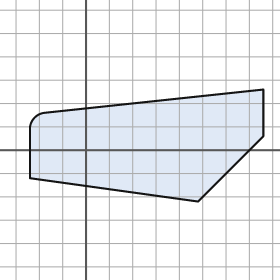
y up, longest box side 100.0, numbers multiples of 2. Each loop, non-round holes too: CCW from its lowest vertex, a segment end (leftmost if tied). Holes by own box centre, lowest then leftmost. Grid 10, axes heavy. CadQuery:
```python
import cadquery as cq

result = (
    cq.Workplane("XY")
    .moveTo(48.0, -22.0)
    .lineTo(76.0, 6.0)
    .lineTo(76.0, 26.0)
    .lineTo(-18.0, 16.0)
    .threePointArc((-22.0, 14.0), (-24.0, 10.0))
    .lineTo(-24.0, -12.0)
    .close()
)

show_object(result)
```